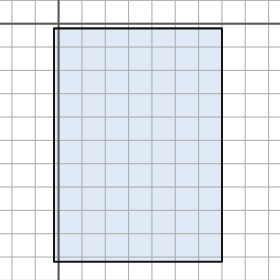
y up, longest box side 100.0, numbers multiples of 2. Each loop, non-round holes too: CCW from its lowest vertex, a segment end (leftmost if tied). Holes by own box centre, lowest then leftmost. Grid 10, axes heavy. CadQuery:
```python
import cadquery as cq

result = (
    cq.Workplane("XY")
    .moveTo(-2.0, -102.0)
    .lineTo(70.0, -102.0)
    .lineTo(70.0, -2.0)
    .lineTo(-2.0, -2.0)
    .close()
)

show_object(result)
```